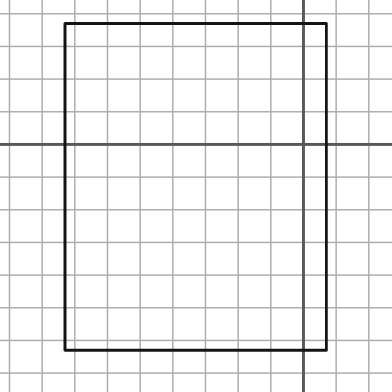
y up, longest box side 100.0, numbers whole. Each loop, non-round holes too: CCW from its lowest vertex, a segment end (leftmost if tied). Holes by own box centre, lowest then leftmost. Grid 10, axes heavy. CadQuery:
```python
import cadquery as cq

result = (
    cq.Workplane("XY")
    .moveTo(-73.0, -63.0)
    .lineTo(7.0, -63.0)
    .lineTo(7.0, 37.0)
    .lineTo(-73.0, 37.0)
    .close()
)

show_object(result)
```